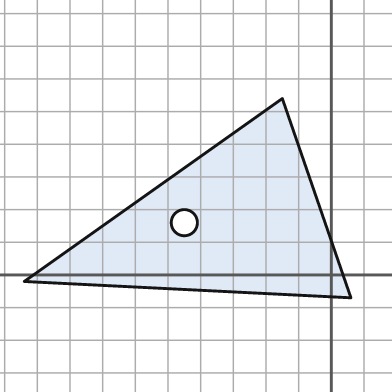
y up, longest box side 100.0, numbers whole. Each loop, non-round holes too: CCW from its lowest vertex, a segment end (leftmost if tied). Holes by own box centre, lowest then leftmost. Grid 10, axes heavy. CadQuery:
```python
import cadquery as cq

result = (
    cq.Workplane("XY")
    .moveTo(6.0, -7.0)
    .lineTo(-15.0, 54.0)
    .lineTo(-94.0, -2.0)
    .close()
    .moveTo(-45.0, 16.0)
    .circle(4.0)
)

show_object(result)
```